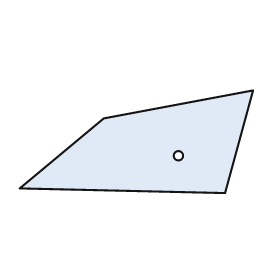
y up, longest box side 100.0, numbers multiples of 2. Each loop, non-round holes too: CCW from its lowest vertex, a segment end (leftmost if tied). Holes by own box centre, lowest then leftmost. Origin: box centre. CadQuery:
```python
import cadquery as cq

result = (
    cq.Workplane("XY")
    .moveTo(38.0, -22.0)
    .lineTo(50.0, 22.0)
    .lineTo(-14.0, 10.0)
    .lineTo(-50.0, -20.0)
    .close()
    .moveTo(18.0, -6.0)
    .circle(2.0)
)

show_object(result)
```